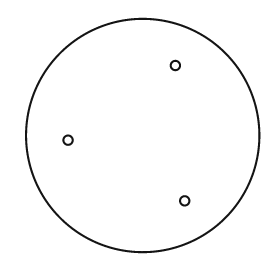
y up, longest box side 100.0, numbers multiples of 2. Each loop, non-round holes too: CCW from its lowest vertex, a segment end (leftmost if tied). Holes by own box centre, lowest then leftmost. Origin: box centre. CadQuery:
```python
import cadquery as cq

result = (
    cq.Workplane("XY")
    .moveTo(0.0, 0.0)
    .circle(50.0)
    .moveTo(18.0, -28.0)
    .circle(2.0)
    .moveTo(-32.0, -2.0)
    .circle(2.0)
    .moveTo(14.0, 30.0)
    .circle(2.0)
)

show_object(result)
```